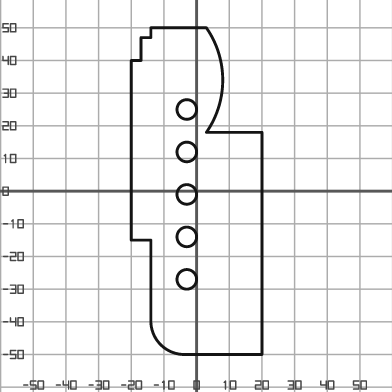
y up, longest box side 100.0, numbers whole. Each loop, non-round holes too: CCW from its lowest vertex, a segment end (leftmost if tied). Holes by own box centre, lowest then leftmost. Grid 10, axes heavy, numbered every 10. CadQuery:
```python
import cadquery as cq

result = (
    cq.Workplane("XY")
    .moveTo(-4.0, -50.0)
    .lineTo(20.0, -50.0)
    .lineTo(20.0, 18.0)
    .lineTo(3.0, 18.0)
    .threePointArc((8.0, 34.0), (3.0, 50.0))
    .lineTo(-14.0, 50.0)
    .lineTo(-14.0, 47.0)
    .lineTo(-17.0, 47.0)
    .lineTo(-17.0, 40.0)
    .lineTo(-20.0, 40.0)
    .lineTo(-20.0, -15.0)
    .lineTo(-14.0, -15.0)
    .lineTo(-14.0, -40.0)
    .threePointArc((-11.0, -47.0), (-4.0, -50.0))
    .close()
    .moveTo(-3.0, -27.0)
    .circle(3.0)
    .moveTo(-3.0, -14.0)
    .circle(3.0)
    .moveTo(-3.0, -1.0)
    .circle(3.0)
    .moveTo(-3.0, 12.0)
    .circle(3.0)
    .moveTo(-3.0, 25.0)
    .circle(3.0)
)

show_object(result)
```